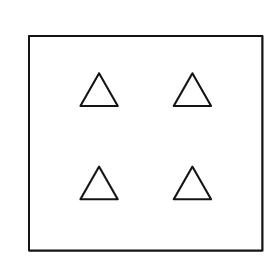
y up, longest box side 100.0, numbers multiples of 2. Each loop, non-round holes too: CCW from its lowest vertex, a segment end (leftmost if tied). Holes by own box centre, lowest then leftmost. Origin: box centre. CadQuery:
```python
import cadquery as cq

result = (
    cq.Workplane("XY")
    .moveTo(-50.0, -46.0)
    .lineTo(50.0, -46.0)
    .lineTo(50.0, 46.0)
    .lineTo(-50.0, 46.0)
    .close()
    .moveTo(-28.0, -24.0)
    .lineTo(-12.0, -24.0)
    .lineTo(-20.0, -10.0)
    .close()
    .moveTo(12.0, -24.0)
    .lineTo(28.0, -24.0)
    .lineTo(20.0, -10.0)
    .close()
    .moveTo(-28.0, 16.0)
    .lineTo(-12.0, 16.0)
    .lineTo(-20.0, 30.0)
    .close()
    .moveTo(12.0, 16.0)
    .lineTo(28.0, 16.0)
    .lineTo(20.0, 30.0)
    .close()
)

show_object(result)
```